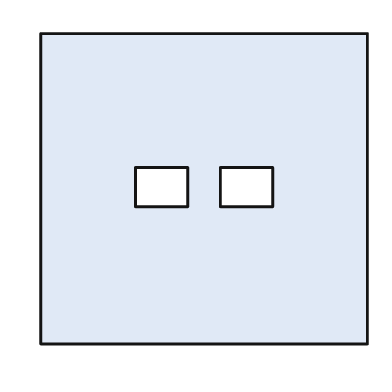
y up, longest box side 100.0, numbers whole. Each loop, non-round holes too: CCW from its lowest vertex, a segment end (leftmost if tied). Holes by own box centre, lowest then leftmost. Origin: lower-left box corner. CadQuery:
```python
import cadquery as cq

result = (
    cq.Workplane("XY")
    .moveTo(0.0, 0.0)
    .lineTo(100.0, 0.0)
    .lineTo(100.0, 95.0)
    .lineTo(0.0, 95.0)
    .close()
    .moveTo(29.0, 42.0)
    .lineTo(45.0, 42.0)
    .lineTo(45.0, 54.0)
    .lineTo(29.0, 54.0)
    .close()
    .moveTo(55.0, 42.0)
    .lineTo(71.0, 42.0)
    .lineTo(71.0, 54.0)
    .lineTo(55.0, 54.0)
    .close()
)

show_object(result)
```